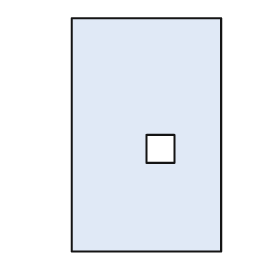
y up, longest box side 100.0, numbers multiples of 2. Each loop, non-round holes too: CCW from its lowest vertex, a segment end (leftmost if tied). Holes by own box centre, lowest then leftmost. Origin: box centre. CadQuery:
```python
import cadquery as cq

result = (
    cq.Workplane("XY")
    .moveTo(-32.0, -50.0)
    .lineTo(32.0, -50.0)
    .lineTo(32.0, 50.0)
    .lineTo(-32.0, 50.0)
    .close()
    .moveTo(0.0, -12.0)
    .lineTo(12.0, -12.0)
    .lineTo(12.0, 0.0)
    .lineTo(0.0, 0.0)
    .close()
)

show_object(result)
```